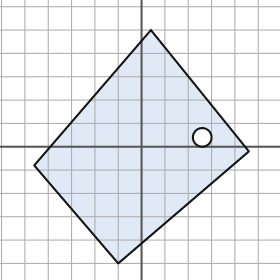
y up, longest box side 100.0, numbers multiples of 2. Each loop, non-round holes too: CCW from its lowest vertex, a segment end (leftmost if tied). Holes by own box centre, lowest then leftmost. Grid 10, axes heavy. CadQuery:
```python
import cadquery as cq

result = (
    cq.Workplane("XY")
    .moveTo(-10.0, -50.0)
    .lineTo(46.0, -2.0)
    .lineTo(4.0, 50.0)
    .lineTo(-46.0, -8.0)
    .close()
    .moveTo(26.0, 4.0)
    .circle(4.0)
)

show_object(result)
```